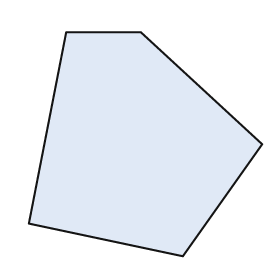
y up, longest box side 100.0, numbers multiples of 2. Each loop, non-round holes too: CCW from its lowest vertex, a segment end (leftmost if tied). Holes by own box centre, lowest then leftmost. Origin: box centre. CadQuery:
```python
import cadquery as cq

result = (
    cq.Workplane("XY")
    .moveTo(16.0, -48.0)
    .lineTo(50.0, 0.0)
    .lineTo(-2.0, 48.0)
    .lineTo(-34.0, 48.0)
    .lineTo(-50.0, -34.0)
    .close()
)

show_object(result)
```